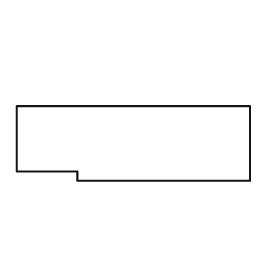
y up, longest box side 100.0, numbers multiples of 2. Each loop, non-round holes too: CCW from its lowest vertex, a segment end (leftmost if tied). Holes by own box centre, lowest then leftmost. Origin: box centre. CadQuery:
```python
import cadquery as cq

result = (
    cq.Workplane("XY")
    .moveTo(-24.0, -16.0)
    .lineTo(50.0, -16.0)
    .lineTo(50.0, 16.0)
    .lineTo(-50.0, 16.0)
    .lineTo(-50.0, -12.0)
    .lineTo(-24.0, -12.0)
    .close()
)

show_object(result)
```